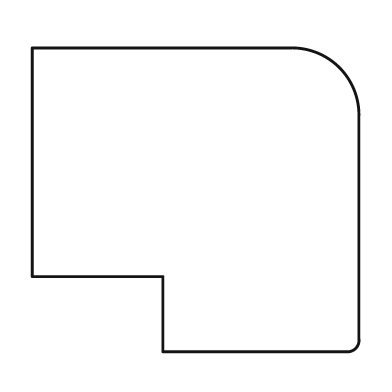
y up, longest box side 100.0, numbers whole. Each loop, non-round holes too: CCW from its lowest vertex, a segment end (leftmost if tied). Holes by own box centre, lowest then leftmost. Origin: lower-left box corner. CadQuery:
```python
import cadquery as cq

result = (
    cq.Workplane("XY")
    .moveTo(40.0, 0.0)
    .lineTo(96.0, 0.0)
    .threePointArc((99.0, 1.0), (100.0, 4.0))
    .lineTo(100.0, 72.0)
    .threePointArc((94.0, 87.0), (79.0, 93.0))
    .lineTo(0.0, 93.0)
    .lineTo(0.0, 23.0)
    .lineTo(40.0, 23.0)
    .close()
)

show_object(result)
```